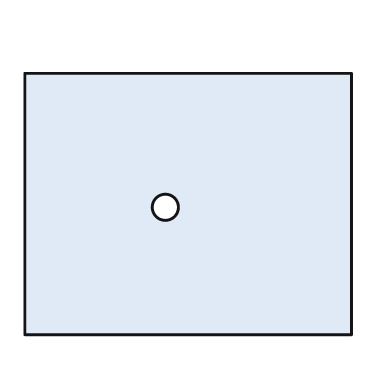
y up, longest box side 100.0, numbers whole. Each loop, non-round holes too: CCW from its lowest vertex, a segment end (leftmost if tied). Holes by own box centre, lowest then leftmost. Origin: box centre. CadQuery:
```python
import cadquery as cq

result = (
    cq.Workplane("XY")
    .moveTo(-50.0, -40.0)
    .lineTo(50.0, -40.0)
    .lineTo(50.0, 40.0)
    .lineTo(-50.0, 40.0)
    .close()
    .moveTo(-7.0, -1.0)
    .circle(4.0)
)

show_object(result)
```